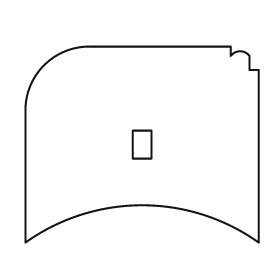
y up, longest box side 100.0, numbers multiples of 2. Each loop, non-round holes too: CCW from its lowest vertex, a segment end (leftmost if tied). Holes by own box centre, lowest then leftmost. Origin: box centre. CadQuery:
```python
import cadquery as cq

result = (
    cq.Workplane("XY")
    .moveTo(-50.0, -42.0)
    .threePointArc((0.0, -26.0), (50.0, -42.0))
    .lineTo(50.0, 32.0)
    .lineTo(46.0, 32.0)
    .lineTo(46.0, 38.0)
    .threePointArc((42.0, 40.0), (38.0, 38.0))
    .lineTo(38.0, 42.0)
    .lineTo(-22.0, 42.0)
    .threePointArc((-42.0, 34.0), (-50.0, 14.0))
    .close()
    .moveTo(-4.0, -6.0)
    .lineTo(4.0, -6.0)
    .lineTo(4.0, 6.0)
    .lineTo(-4.0, 6.0)
    .close()
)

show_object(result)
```